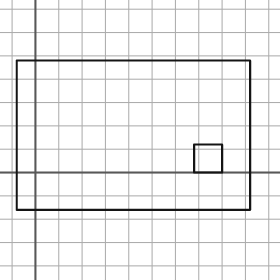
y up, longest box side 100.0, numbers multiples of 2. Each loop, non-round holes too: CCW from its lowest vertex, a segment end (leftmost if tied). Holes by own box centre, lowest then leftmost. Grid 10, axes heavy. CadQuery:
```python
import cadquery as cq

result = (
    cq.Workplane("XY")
    .moveTo(-8.0, -16.0)
    .lineTo(92.0, -16.0)
    .lineTo(92.0, 48.0)
    .lineTo(-8.0, 48.0)
    .close()
    .moveTo(68.0, 0.0)
    .lineTo(80.0, 0.0)
    .lineTo(80.0, 12.0)
    .lineTo(68.0, 12.0)
    .close()
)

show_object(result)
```